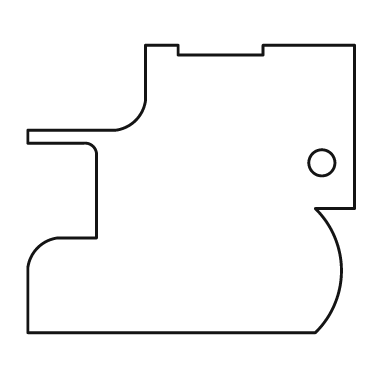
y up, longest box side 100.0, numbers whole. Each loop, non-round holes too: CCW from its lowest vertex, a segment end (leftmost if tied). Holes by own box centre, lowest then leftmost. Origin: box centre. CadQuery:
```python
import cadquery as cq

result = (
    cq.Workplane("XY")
    .moveTo(-50.0, -44.0)
    .lineTo(38.0, -44.0)
    .threePointArc((46.0, -25.0), (38.0, -6.0))
    .lineTo(50.0, -6.0)
    .lineTo(50.0, 44.0)
    .lineTo(22.0, 44.0)
    .lineTo(22.0, 41.0)
    .lineTo(-4.0, 41.0)
    .lineTo(-4.0, 44.0)
    .lineTo(-14.0, 44.0)
    .lineTo(-14.0, 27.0)
    .threePointArc((-17.0, 21.0), (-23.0, 18.0))
    .lineTo(-50.0, 18.0)
    .lineTo(-50.0, 14.0)
    .lineTo(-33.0, 14.0)
    .threePointArc((-30.0, 13.0), (-29.0, 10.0))
    .lineTo(-29.0, -15.0)
    .lineTo(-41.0, -15.0)
    .threePointArc((-47.0, -18.0), (-50.0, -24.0))
    .close()
    .moveTo(40.0, 8.0)
    .circle(4.0)
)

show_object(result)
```